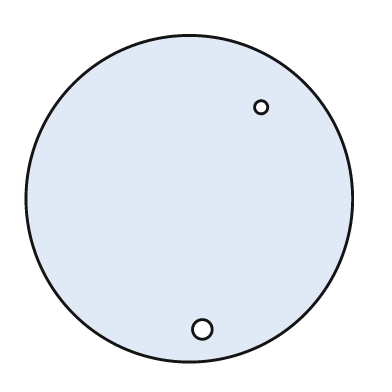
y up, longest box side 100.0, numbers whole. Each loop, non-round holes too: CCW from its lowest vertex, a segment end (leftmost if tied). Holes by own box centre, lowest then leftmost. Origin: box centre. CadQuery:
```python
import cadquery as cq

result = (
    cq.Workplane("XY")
    .moveTo(0.0, 0.0)
    .circle(50.0)
    .moveTo(4.0, -40.0)
    .circle(3.0)
    .moveTo(22.0, 28.0)
    .circle(2.0)
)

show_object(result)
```